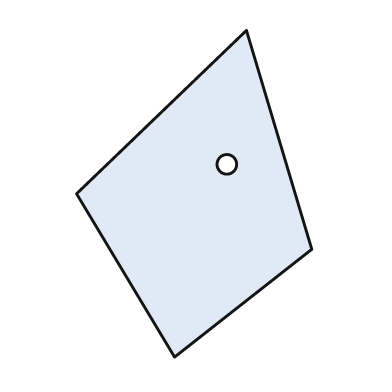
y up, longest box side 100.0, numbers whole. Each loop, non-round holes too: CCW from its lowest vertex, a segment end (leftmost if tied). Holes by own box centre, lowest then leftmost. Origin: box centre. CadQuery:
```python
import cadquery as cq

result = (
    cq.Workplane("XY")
    .moveTo(-6.0, -50.0)
    .lineTo(36.0, -17.0)
    .lineTo(16.0, 50.0)
    .lineTo(-36.0, 0.0)
    .close()
    .moveTo(10.0, 9.0)
    .circle(3.0)
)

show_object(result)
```